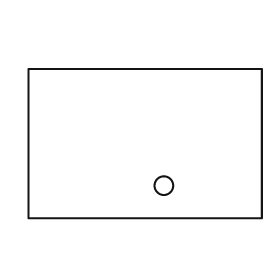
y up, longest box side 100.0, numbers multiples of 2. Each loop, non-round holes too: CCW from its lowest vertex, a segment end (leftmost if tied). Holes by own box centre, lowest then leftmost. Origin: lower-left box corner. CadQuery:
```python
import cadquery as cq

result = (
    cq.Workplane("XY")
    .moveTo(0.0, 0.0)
    .lineTo(100.0, 0.0)
    .lineTo(100.0, 64.0)
    .lineTo(0.0, 64.0)
    .close()
    .moveTo(58.0, 14.0)
    .circle(4.0)
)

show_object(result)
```